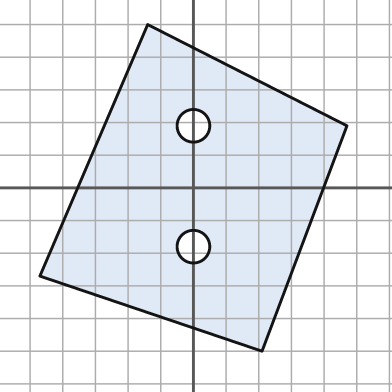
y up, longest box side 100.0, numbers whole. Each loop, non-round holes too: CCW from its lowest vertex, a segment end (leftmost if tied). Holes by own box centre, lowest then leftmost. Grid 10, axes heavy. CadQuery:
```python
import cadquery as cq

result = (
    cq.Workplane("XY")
    .moveTo(21.0, -50.0)
    .lineTo(47.0, 19.0)
    .lineTo(-14.0, 50.0)
    .lineTo(-47.0, -27.0)
    .close()
    .moveTo(0.0, -18.0)
    .circle(5.0)
    .moveTo(0.0, 19.0)
    .circle(5.0)
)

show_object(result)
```